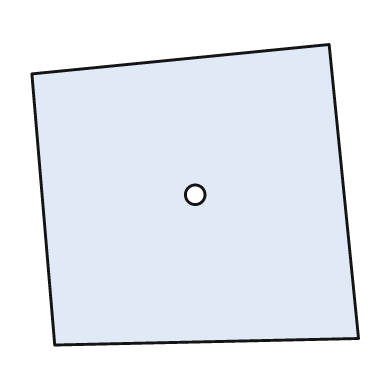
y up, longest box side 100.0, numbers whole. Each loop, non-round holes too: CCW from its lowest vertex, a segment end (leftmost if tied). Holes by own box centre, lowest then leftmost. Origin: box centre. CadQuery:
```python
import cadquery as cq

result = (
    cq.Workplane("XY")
    .moveTo(-43.0, -46.0)
    .lineTo(50.0, -44.0)
    .lineTo(41.0, 46.0)
    .lineTo(-50.0, 37.0)
    .close()
    .moveTo(0.0, 0.0)
    .circle(3.0)
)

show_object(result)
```